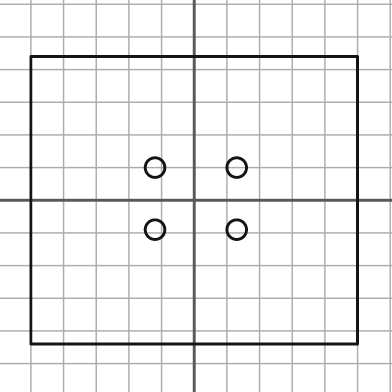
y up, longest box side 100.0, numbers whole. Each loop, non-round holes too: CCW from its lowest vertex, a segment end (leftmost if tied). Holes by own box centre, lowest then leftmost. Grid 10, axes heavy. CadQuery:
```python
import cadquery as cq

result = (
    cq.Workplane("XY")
    .moveTo(-50.0, -44.0)
    .lineTo(50.0, -44.0)
    .lineTo(50.0, 44.0)
    .lineTo(-50.0, 44.0)
    .close()
    .moveTo(-12.0, -9.0)
    .circle(3.0)
    .moveTo(13.0, -9.0)
    .circle(3.0)
    .moveTo(-12.0, 10.0)
    .circle(3.0)
    .moveTo(13.0, 10.0)
    .circle(3.0)
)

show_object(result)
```